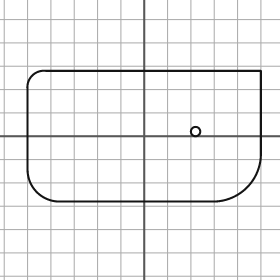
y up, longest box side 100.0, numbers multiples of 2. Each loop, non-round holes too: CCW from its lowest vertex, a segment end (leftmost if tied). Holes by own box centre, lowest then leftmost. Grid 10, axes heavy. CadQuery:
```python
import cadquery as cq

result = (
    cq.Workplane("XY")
    .moveTo(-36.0, -28.0)
    .lineTo(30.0, -28.0)
    .threePointArc((44.0, -22.0), (50.0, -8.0))
    .lineTo(50.0, 28.0)
    .lineTo(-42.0, 28.0)
    .threePointArc((-48.0, 26.0), (-50.0, 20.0))
    .lineTo(-50.0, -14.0)
    .threePointArc((-46.0, -24.0), (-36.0, -28.0))
    .close()
    .moveTo(22.0, 2.0)
    .circle(2.0)
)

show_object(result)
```